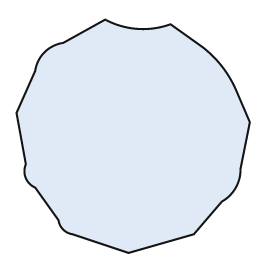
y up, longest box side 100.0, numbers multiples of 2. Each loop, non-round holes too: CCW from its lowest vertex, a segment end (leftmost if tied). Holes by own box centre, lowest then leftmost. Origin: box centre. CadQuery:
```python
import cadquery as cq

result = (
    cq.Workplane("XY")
    .moveTo(-2.0, -50.0)
    .lineTo(26.0, -42.0)
    .lineTo(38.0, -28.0)
    .threePointArc((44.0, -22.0), (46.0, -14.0))
    .lineTo(50.0, 6.0)
    .lineTo(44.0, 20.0)
    .threePointArc((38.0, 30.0), (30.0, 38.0))
    .lineTo(16.0, 48.0)
    .threePointArc((2.0, 46.0), (-12.0, 50.0))
    .lineTo(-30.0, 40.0)
    .threePointArc((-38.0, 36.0), (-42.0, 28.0))
    .lineTo(-50.0, 10.0)
    .lineTo(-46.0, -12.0)
    .threePointArc((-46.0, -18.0), (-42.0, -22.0))
    .lineTo(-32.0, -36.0)
    .threePointArc((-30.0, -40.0), (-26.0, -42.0))
    .close()
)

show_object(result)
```